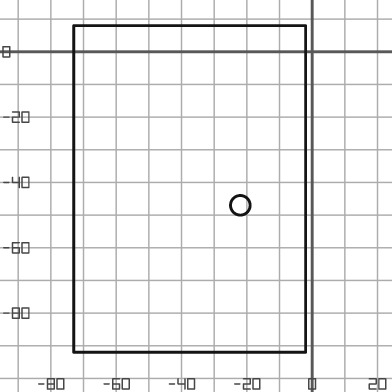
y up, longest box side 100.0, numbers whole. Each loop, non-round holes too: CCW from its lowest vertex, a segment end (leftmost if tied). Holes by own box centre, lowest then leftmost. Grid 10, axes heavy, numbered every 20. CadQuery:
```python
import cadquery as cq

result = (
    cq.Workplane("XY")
    .moveTo(-73.0, -92.0)
    .lineTo(-2.0, -92.0)
    .lineTo(-2.0, 8.0)
    .lineTo(-73.0, 8.0)
    .close()
    .moveTo(-22.0, -47.0)
    .circle(3.0)
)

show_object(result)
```